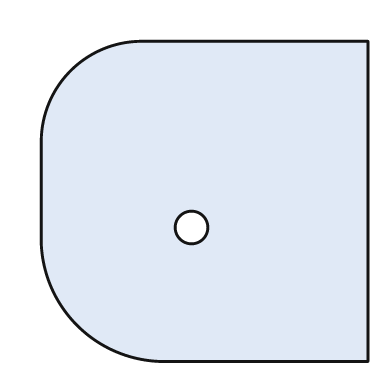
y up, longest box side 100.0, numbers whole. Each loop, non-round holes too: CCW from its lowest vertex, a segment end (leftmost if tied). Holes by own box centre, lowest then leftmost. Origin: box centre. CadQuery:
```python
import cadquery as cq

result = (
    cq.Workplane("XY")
    .moveTo(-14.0, -49.0)
    .lineTo(50.0, -49.0)
    .lineTo(50.0, 49.0)
    .lineTo(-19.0, 49.0)
    .threePointArc((-41.0, 40.0), (-50.0, 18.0))
    .lineTo(-50.0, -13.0)
    .threePointArc((-39.0, -38.0), (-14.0, -49.0))
    .close()
    .moveTo(-4.0, -8.0)
    .circle(5.0)
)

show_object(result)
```